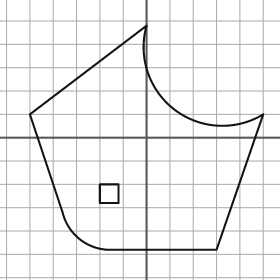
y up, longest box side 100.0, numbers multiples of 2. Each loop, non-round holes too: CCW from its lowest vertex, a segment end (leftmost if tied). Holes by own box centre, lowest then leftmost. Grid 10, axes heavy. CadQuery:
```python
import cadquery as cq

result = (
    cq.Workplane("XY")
    .moveTo(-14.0, -48.0)
    .lineTo(30.0, -48.0)
    .lineTo(50.0, 10.0)
    .threePointArc((12.0, 12.0), (0.0, 48.0))
    .lineTo(-50.0, 10.0)
    .lineTo(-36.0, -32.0)
    .threePointArc((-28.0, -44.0), (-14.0, -48.0))
    .close()
    .moveTo(-20.0, -28.0)
    .lineTo(-12.0, -28.0)
    .lineTo(-12.0, -20.0)
    .lineTo(-20.0, -20.0)
    .close()
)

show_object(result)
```